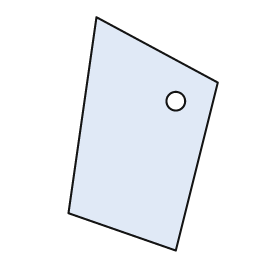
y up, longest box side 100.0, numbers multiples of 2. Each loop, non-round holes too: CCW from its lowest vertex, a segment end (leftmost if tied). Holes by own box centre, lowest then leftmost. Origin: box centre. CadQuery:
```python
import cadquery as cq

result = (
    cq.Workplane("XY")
    .moveTo(14.0, -50.0)
    .lineTo(32.0, 22.0)
    .lineTo(-20.0, 50.0)
    .lineTo(-32.0, -34.0)
    .close()
    .moveTo(14.0, 14.0)
    .circle(4.0)
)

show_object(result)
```